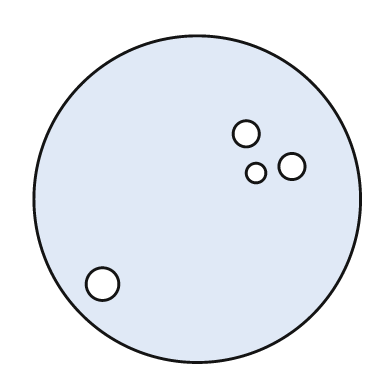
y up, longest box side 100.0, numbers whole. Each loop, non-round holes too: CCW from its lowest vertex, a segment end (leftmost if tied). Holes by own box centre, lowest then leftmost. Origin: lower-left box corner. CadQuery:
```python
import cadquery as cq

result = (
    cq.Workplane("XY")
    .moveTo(50.0, 50.0)
    .circle(50.0)
    .moveTo(21.0, 24.0)
    .circle(5.0)
    .moveTo(68.0, 58.0)
    .circle(3.0)
    .moveTo(79.0, 60.0)
    .circle(4.0)
    .moveTo(65.0, 70.0)
    .circle(4.0)
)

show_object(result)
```